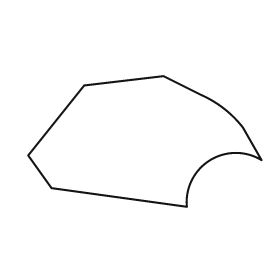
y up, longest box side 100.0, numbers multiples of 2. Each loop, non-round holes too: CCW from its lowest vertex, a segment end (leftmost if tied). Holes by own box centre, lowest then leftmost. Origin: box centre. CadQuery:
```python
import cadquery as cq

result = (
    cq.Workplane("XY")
    .moveTo(18.0, -28.0)
    .threePointArc((28.0, -8.0), (50.0, -8.0))
    .lineTo(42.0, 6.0)
    .threePointArc((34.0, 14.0), (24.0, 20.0))
    .lineTo(8.0, 28.0)
    .lineTo(-26.0, 24.0)
    .lineTo(-50.0, -6.0)
    .lineTo(-40.0, -20.0)
    .close()
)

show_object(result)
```